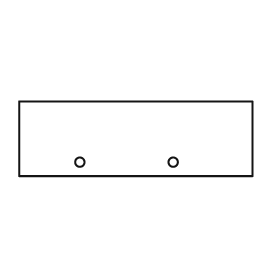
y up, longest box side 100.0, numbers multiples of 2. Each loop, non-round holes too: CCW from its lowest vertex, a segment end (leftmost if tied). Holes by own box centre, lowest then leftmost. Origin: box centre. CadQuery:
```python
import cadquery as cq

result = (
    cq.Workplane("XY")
    .moveTo(-50.0, -16.0)
    .lineTo(50.0, -16.0)
    .lineTo(50.0, 16.0)
    .lineTo(-50.0, 16.0)
    .close()
    .moveTo(-24.0, -10.0)
    .circle(2.0)
    .moveTo(16.0, -10.0)
    .circle(2.0)
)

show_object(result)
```